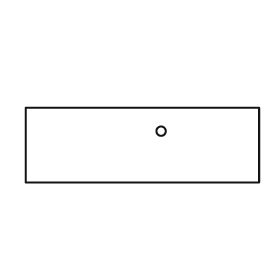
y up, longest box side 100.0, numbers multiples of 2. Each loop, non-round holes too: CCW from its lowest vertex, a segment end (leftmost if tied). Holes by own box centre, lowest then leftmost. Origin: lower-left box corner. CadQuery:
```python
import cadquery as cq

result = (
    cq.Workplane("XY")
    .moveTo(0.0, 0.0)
    .lineTo(100.0, 0.0)
    .lineTo(100.0, 32.0)
    .lineTo(0.0, 32.0)
    .close()
    .moveTo(58.0, 22.0)
    .circle(2.0)
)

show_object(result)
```